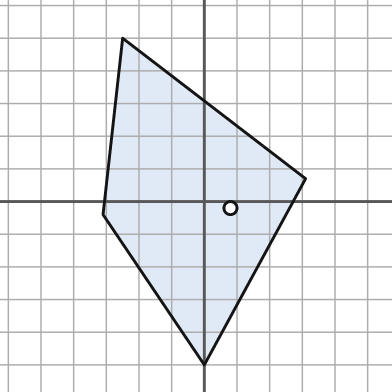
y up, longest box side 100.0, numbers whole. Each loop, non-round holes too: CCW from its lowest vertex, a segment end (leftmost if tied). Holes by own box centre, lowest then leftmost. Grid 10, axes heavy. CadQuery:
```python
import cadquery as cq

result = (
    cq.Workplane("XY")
    .moveTo(0.0, -50.0)
    .lineTo(31.0, 7.0)
    .lineTo(-25.0, 50.0)
    .lineTo(-31.0, -4.0)
    .close()
    .moveTo(8.0, -2.0)
    .circle(2.0)
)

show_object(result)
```